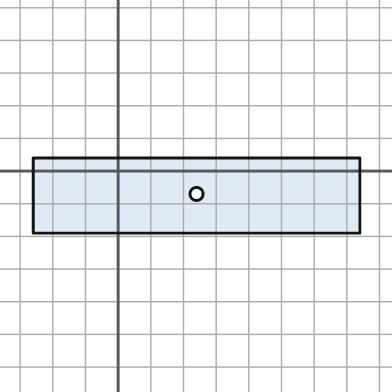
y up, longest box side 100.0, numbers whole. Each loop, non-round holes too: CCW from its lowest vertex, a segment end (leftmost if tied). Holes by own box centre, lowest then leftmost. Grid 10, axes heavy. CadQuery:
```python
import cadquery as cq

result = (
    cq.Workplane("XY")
    .moveTo(-26.0, -19.0)
    .lineTo(74.0, -19.0)
    .lineTo(74.0, 4.0)
    .lineTo(-26.0, 4.0)
    .close()
    .moveTo(24.0, -7.0)
    .circle(2.0)
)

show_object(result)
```